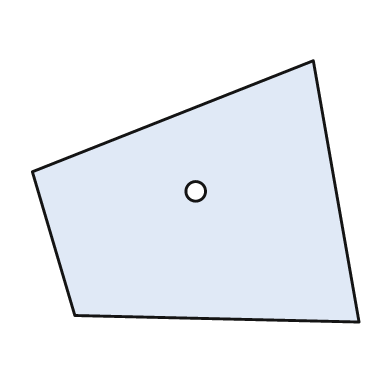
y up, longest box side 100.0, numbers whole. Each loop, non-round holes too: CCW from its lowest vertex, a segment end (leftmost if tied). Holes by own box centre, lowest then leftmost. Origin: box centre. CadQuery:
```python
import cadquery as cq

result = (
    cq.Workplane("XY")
    .moveTo(50.0, -40.0)
    .lineTo(36.0, 40.0)
    .lineTo(-50.0, 6.0)
    .lineTo(-37.0, -38.0)
    .close()
    .moveTo(0.0, 0.0)
    .circle(3.0)
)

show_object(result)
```